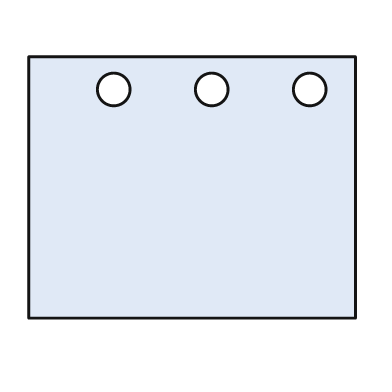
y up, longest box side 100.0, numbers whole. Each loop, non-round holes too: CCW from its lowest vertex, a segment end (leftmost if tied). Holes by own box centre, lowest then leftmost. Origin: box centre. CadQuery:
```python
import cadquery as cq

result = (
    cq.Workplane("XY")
    .moveTo(-50.0, -40.0)
    .lineTo(50.0, -40.0)
    .lineTo(50.0, 40.0)
    .lineTo(-50.0, 40.0)
    .close()
    .moveTo(-24.0, 30.0)
    .circle(5.0)
    .moveTo(6.0, 30.0)
    .circle(5.0)
    .moveTo(36.0, 30.0)
    .circle(5.0)
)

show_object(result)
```